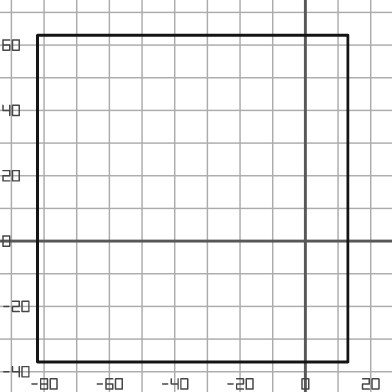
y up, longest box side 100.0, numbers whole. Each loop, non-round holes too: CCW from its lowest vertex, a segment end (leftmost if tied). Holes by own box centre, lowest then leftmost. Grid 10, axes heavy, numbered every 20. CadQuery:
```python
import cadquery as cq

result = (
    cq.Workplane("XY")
    .moveTo(-82.0, -37.0)
    .lineTo(13.0, -37.0)
    .lineTo(13.0, 63.0)
    .lineTo(-82.0, 63.0)
    .close()
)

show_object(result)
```